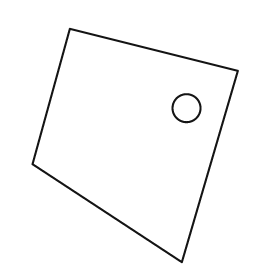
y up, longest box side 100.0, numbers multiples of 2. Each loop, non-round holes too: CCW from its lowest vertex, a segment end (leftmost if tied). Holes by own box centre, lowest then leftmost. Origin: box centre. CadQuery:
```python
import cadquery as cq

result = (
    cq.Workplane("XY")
    .moveTo(20.0, -50.0)
    .lineTo(44.0, 32.0)
    .lineTo(-28.0, 50.0)
    .lineTo(-44.0, -8.0)
    .close()
    .moveTo(22.0, 16.0)
    .circle(6.0)
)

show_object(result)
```